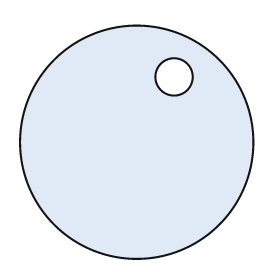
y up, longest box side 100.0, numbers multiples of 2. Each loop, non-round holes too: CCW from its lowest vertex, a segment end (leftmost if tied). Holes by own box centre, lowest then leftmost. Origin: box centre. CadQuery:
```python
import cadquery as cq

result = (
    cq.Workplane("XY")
    .moveTo(0.0, 0.0)
    .circle(50.0)
    .moveTo(16.0, 28.0)
    .circle(8.0)
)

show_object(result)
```